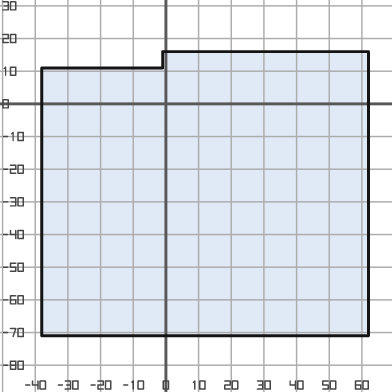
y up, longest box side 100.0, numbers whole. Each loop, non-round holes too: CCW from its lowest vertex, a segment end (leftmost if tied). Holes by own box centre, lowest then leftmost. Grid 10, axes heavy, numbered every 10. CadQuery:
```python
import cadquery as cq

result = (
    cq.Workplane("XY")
    .moveTo(-38.0, -71.0)
    .lineTo(62.0, -71.0)
    .lineTo(62.0, 16.0)
    .lineTo(-1.0, 16.0)
    .lineTo(-1.0, 11.0)
    .lineTo(-38.0, 11.0)
    .close()
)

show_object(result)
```